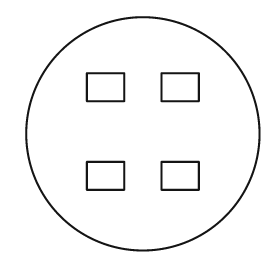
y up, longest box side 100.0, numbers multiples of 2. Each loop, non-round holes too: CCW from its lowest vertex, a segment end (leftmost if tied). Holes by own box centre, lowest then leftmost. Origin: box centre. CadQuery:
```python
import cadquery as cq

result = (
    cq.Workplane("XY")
    .moveTo(0.0, 0.0)
    .circle(50.0)
    .moveTo(-24.0, -24.0)
    .lineTo(-8.0, -24.0)
    .lineTo(-8.0, -12.0)
    .lineTo(-24.0, -12.0)
    .close()
    .moveTo(8.0, -24.0)
    .lineTo(24.0, -24.0)
    .lineTo(24.0, -12.0)
    .lineTo(8.0, -12.0)
    .close()
    .moveTo(-24.0, 14.0)
    .lineTo(-8.0, 14.0)
    .lineTo(-8.0, 26.0)
    .lineTo(-24.0, 26.0)
    .close()
    .moveTo(8.0, 14.0)
    .lineTo(24.0, 14.0)
    .lineTo(24.0, 26.0)
    .lineTo(8.0, 26.0)
    .close()
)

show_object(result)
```